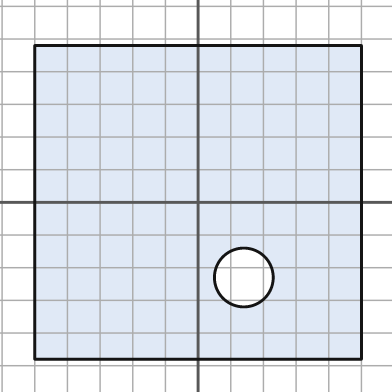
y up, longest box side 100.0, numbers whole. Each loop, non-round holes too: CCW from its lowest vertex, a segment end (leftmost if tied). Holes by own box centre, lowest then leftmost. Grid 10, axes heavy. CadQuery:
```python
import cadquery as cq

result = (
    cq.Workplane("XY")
    .moveTo(-50.0, -48.0)
    .lineTo(50.0, -48.0)
    .lineTo(50.0, 48.0)
    .lineTo(-50.0, 48.0)
    .close()
    .moveTo(14.0, -23.0)
    .circle(9.0)
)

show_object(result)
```